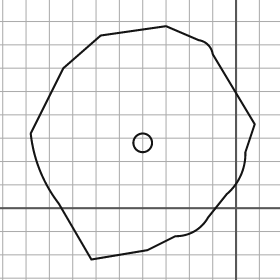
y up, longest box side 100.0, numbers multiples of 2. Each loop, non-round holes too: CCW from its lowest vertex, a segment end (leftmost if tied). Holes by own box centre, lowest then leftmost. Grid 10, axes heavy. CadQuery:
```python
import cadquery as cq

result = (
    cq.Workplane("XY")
    .moveTo(-62.0, -22.0)
    .lineTo(-38.0, -18.0)
    .lineTo(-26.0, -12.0)
    .threePointArc((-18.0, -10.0), (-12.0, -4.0))
    .lineTo(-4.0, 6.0)
    .threePointArc((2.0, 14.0), (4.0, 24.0))
    .lineTo(8.0, 36.0)
    .lineTo(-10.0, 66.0)
    .threePointArc((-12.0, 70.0), (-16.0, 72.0))
    .lineTo(-30.0, 78.0)
    .lineTo(-58.0, 74.0)
    .lineTo(-74.0, 60.0)
    .lineTo(-88.0, 32.0)
    .threePointArc((-84.0, 16.0), (-76.0, 2.0))
    .close()
    .moveTo(-40.0, 28.0)
    .circle(4.0)
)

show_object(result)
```